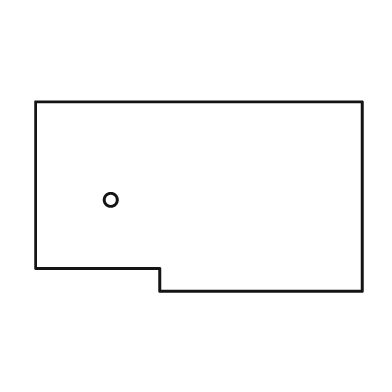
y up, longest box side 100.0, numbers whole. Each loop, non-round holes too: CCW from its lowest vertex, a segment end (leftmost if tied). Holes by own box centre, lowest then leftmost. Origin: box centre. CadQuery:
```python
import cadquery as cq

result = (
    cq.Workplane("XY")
    .moveTo(-12.0, -29.0)
    .lineTo(50.0, -29.0)
    .lineTo(50.0, 29.0)
    .lineTo(-50.0, 29.0)
    .lineTo(-50.0, -22.0)
    .lineTo(-12.0, -22.0)
    .close()
    .moveTo(-27.0, -1.0)
    .circle(2.0)
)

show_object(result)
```